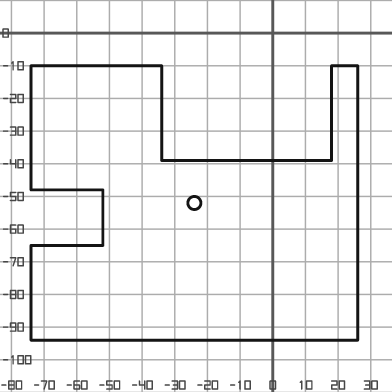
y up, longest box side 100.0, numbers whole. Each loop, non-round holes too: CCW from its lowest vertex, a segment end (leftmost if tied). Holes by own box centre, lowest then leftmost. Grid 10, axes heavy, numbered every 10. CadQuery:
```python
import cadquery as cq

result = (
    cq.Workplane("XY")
    .moveTo(-74.0, -94.0)
    .lineTo(26.0, -94.0)
    .lineTo(26.0, -10.0)
    .lineTo(18.0, -10.0)
    .lineTo(18.0, -39.0)
    .lineTo(-34.0, -39.0)
    .lineTo(-34.0, -10.0)
    .lineTo(-74.0, -10.0)
    .lineTo(-74.0, -48.0)
    .lineTo(-52.0, -48.0)
    .lineTo(-52.0, -65.0)
    .lineTo(-74.0, -65.0)
    .close()
    .moveTo(-24.0, -52.0)
    .circle(2.0)
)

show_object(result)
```